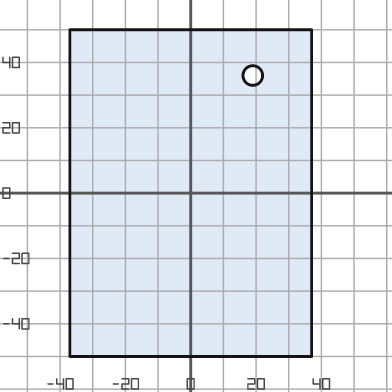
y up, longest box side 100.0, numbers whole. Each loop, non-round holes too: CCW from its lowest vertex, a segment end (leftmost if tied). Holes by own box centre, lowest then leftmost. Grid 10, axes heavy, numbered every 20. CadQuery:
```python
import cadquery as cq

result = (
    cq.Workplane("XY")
    .moveTo(-37.0, -50.0)
    .lineTo(37.0, -50.0)
    .lineTo(37.0, 50.0)
    .lineTo(-37.0, 50.0)
    .close()
    .moveTo(19.0, 36.0)
    .circle(3.0)
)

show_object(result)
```